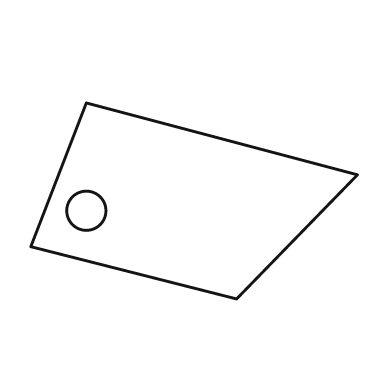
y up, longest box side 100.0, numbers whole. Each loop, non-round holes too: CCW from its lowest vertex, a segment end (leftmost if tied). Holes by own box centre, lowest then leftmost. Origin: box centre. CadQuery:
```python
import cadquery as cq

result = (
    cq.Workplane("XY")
    .moveTo(13.0, -30.0)
    .lineTo(50.0, 8.0)
    .lineTo(-33.0, 30.0)
    .lineTo(-50.0, -14.0)
    .close()
    .moveTo(-33.0, -3.0)
    .circle(6.0)
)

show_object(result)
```